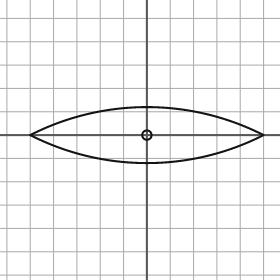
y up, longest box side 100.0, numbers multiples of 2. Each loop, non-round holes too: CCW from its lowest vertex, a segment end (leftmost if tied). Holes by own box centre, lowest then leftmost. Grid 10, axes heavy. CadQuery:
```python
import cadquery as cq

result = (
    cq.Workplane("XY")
    .moveTo(-50.0, 0.0)
    .threePointArc((0.0, -12.0), (50.0, 0.0))
    .threePointArc((0.0, 12.0), (-50.0, 0.0))
    .close()
    .moveTo(0.0, 0.0)
    .circle(2.0)
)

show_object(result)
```